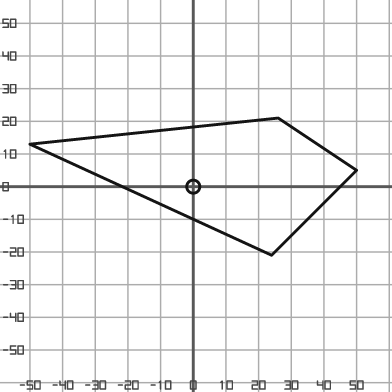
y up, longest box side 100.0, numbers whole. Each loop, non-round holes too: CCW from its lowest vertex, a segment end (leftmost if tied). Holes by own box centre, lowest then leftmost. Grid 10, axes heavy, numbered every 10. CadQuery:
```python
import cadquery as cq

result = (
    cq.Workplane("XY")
    .moveTo(24.0, -21.0)
    .lineTo(50.0, 5.0)
    .lineTo(26.0, 21.0)
    .lineTo(-50.0, 13.0)
    .close()
    .moveTo(0.0, 0.0)
    .circle(2.0)
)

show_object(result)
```